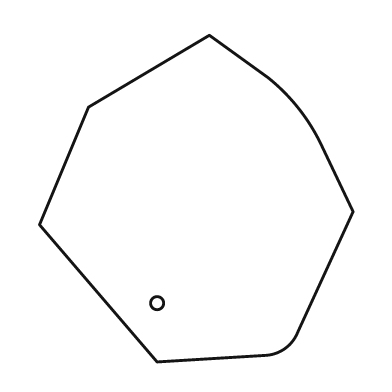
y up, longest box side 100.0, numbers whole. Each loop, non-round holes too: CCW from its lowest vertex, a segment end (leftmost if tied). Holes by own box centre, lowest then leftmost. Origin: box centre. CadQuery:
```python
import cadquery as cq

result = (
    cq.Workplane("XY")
    .moveTo(-12.0, -50.0)
    .lineTo(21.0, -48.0)
    .threePointArc((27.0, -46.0), (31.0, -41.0))
    .lineTo(48.0, -4.0)
    .lineTo(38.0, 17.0)
    .threePointArc((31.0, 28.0), (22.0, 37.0))
    .lineTo(4.0, 50.0)
    .lineTo(-33.0, 28.0)
    .lineTo(-48.0, -8.0)
    .close()
    .moveTo(-12.0, -32.0)
    .circle(2.0)
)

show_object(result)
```